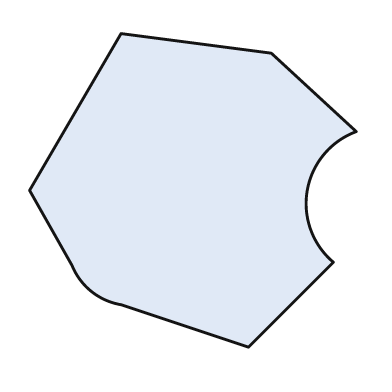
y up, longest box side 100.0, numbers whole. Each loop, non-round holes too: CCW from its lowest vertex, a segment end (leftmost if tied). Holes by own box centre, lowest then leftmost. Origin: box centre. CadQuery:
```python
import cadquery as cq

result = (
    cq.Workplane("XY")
    .moveTo(17.0, -48.0)
    .lineTo(43.0, -22.0)
    .threePointArc((35.0, 0.0), (50.0, 18.0))
    .lineTo(24.0, 42.0)
    .lineTo(-22.0, 48.0)
    .lineTo(-50.0, 0.0)
    .lineTo(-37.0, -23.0)
    .threePointArc((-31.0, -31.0), (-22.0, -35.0))
    .close()
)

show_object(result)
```